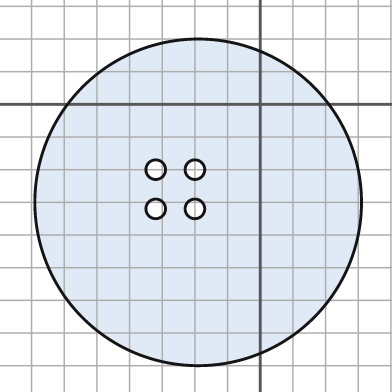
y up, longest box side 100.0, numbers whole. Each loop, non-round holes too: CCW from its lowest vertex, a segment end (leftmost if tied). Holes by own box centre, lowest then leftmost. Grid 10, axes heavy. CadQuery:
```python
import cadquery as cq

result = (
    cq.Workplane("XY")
    .moveTo(-19.0, -30.0)
    .circle(50.0)
    .moveTo(-32.0, -32.0)
    .circle(3.0)
    .moveTo(-20.0, -32.0)
    .circle(3.0)
    .moveTo(-32.0, -20.0)
    .circle(3.0)
    .moveTo(-20.0, -20.0)
    .circle(3.0)
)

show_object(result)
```